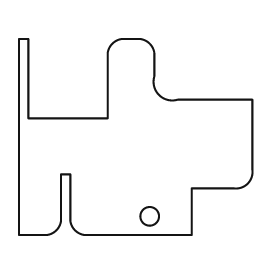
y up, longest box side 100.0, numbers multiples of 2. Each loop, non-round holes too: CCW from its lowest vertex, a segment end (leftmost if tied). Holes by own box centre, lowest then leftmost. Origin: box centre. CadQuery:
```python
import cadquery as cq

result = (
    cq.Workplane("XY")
    .moveTo(-50.0, -42.0)
    .lineTo(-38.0, -42.0)
    .threePointArc((-34.0, -40.0), (-32.0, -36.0))
    .lineTo(-32.0, -16.0)
    .lineTo(-28.0, -16.0)
    .lineTo(-28.0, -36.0)
    .threePointArc((-26.0, -40.0), (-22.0, -42.0))
    .lineTo(24.0, -42.0)
    .lineTo(24.0, -22.0)
    .lineTo(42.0, -22.0)
    .threePointArc((48.0, -20.0), (50.0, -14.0))
    .lineTo(50.0, 16.0)
    .lineTo(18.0, 16.0)
    .threePointArc((10.0, 18.0), (8.0, 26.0))
    .lineTo(8.0, 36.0)
    .threePointArc((6.0, 40.0), (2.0, 42.0))
    .lineTo(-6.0, 42.0)
    .threePointArc((-10.0, 40.0), (-12.0, 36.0))
    .lineTo(-12.0, 8.0)
    .lineTo(-46.0, 8.0)
    .lineTo(-46.0, 42.0)
    .lineTo(-50.0, 42.0)
    .close()
    .moveTo(6.0, -34.0)
    .circle(4.0)
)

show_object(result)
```